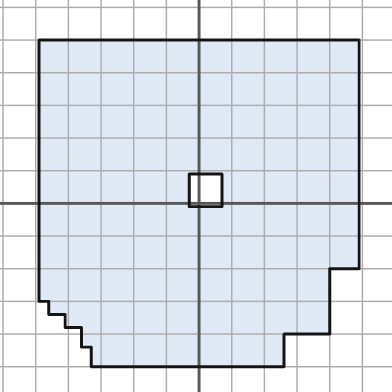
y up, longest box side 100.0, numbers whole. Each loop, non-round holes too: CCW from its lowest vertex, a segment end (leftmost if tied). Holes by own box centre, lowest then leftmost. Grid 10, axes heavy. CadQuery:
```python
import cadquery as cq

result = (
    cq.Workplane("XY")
    .moveTo(-33.0, -50.0)
    .lineTo(26.0, -50.0)
    .lineTo(26.0, -40.0)
    .lineTo(40.0, -40.0)
    .lineTo(40.0, -20.0)
    .lineTo(49.0, -20.0)
    .lineTo(49.0, 50.0)
    .lineTo(-49.0, 50.0)
    .lineTo(-49.0, -30.0)
    .lineTo(-46.0, -30.0)
    .lineTo(-46.0, -34.0)
    .lineTo(-41.0, -34.0)
    .lineTo(-41.0, -38.0)
    .lineTo(-36.0, -38.0)
    .lineTo(-36.0, -44.0)
    .lineTo(-33.0, -44.0)
    .close()
    .moveTo(-3.0, -1.0)
    .lineTo(7.0, -1.0)
    .lineTo(7.0, 9.0)
    .lineTo(-3.0, 9.0)
    .close()
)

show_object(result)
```